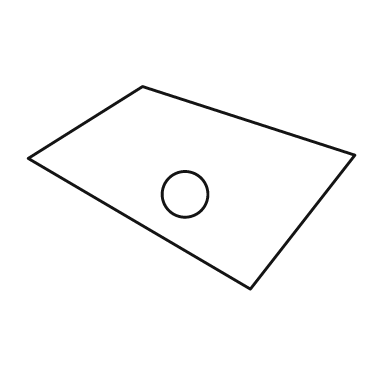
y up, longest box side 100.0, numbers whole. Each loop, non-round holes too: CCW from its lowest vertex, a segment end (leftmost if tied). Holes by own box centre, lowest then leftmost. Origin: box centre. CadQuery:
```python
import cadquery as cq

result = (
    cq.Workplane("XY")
    .moveTo(18.0, -31.0)
    .lineTo(50.0, 10.0)
    .lineTo(-15.0, 31.0)
    .lineTo(-50.0, 9.0)
    .close()
    .moveTo(-2.0, -2.0)
    .circle(7.0)
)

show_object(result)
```